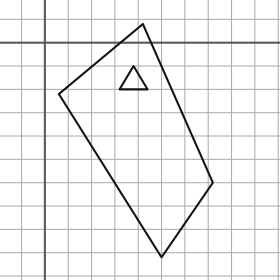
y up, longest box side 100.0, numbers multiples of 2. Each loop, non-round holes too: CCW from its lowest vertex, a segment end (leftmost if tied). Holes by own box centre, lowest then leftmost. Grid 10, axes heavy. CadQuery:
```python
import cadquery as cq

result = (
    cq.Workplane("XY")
    .moveTo(50.0, -92.0)
    .lineTo(72.0, -60.0)
    .lineTo(42.0, 8.0)
    .lineTo(6.0, -22.0)
    .close()
    .moveTo(32.0, -20.0)
    .lineTo(44.0, -20.0)
    .lineTo(38.0, -10.0)
    .close()
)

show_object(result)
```